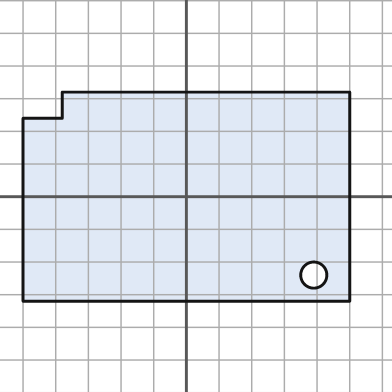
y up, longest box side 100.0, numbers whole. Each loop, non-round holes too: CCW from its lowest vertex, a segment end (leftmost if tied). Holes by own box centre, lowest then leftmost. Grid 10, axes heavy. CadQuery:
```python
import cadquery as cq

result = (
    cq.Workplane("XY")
    .moveTo(-50.0, -32.0)
    .lineTo(50.0, -32.0)
    .lineTo(50.0, 32.0)
    .lineTo(-38.0, 32.0)
    .lineTo(-38.0, 24.0)
    .lineTo(-50.0, 24.0)
    .close()
    .moveTo(39.0, -24.0)
    .circle(4.0)
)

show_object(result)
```